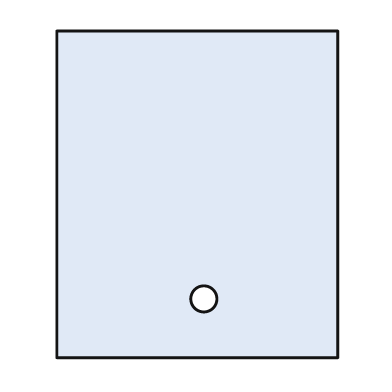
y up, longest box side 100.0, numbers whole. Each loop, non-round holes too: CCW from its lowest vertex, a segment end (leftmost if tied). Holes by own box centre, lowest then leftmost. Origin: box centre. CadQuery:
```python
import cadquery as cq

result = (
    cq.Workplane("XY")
    .moveTo(-43.0, -50.0)
    .lineTo(43.0, -50.0)
    .lineTo(43.0, 50.0)
    .lineTo(-43.0, 50.0)
    .close()
    .moveTo(2.0, -32.0)
    .circle(4.0)
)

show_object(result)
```